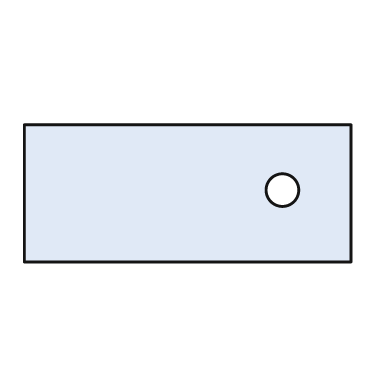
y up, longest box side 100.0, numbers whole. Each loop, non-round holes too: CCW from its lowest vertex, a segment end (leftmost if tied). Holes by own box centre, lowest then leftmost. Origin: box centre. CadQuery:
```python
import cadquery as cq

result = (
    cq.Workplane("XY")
    .moveTo(-50.0, -21.0)
    .lineTo(50.0, -21.0)
    .lineTo(50.0, 21.0)
    .lineTo(-50.0, 21.0)
    .close()
    .moveTo(29.0, 1.0)
    .circle(5.0)
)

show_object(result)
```